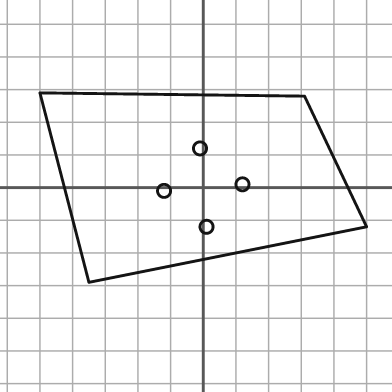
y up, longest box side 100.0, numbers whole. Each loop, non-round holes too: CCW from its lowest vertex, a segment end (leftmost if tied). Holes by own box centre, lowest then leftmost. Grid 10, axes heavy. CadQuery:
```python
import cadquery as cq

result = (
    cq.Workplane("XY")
    .moveTo(-35.0, -29.0)
    .lineTo(50.0, -12.0)
    .lineTo(31.0, 28.0)
    .lineTo(-50.0, 29.0)
    .close()
    .moveTo(1.0, -12.0)
    .circle(2.0)
    .moveTo(-12.0, -1.0)
    .circle(2.0)
    .moveTo(12.0, 1.0)
    .circle(2.0)
    .moveTo(-1.0, 12.0)
    .circle(2.0)
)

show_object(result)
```